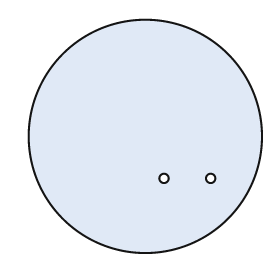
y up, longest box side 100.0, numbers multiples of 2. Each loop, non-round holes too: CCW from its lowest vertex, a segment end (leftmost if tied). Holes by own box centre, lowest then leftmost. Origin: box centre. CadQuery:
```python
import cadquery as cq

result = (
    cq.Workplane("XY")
    .moveTo(0.0, 0.0)
    .circle(50.0)
    .moveTo(8.0, -18.0)
    .circle(2.0)
    .moveTo(28.0, -18.0)
    .circle(2.0)
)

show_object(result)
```